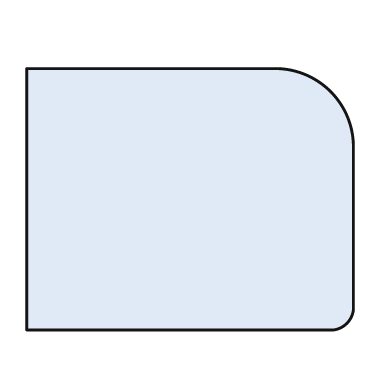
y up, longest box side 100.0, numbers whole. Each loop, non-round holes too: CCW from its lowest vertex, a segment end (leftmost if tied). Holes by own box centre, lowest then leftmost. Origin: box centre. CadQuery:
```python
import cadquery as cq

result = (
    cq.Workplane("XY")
    .moveTo(-50.0, -40.0)
    .lineTo(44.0, -40.0)
    .threePointArc((48.0, -38.0), (50.0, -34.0))
    .lineTo(50.0, 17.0)
    .threePointArc((43.0, 33.0), (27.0, 40.0))
    .lineTo(-50.0, 40.0)
    .close()
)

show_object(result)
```